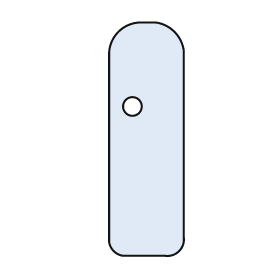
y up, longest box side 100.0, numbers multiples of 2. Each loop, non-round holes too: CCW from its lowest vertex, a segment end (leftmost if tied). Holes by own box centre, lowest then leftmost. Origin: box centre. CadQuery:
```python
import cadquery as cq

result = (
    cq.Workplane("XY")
    .moveTo(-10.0, -50.0)
    .lineTo(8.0, -50.0)
    .threePointArc((14.0, -48.0), (16.0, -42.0))
    .lineTo(16.0, 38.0)
    .threePointArc((12.0, 46.0), (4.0, 50.0))
    .lineTo(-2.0, 50.0)
    .threePointArc((-12.0, 46.0), (-16.0, 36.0))
    .lineTo(-16.0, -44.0)
    .threePointArc((-14.0, -48.0), (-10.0, -50.0))
    .close()
    .moveTo(-6.0, 14.0)
    .circle(4.0)
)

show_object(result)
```